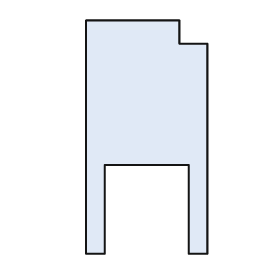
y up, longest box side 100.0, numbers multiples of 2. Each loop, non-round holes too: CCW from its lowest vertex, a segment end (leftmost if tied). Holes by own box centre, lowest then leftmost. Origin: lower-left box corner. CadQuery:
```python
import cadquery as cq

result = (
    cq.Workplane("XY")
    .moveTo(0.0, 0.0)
    .lineTo(8.0, 0.0)
    .lineTo(8.0, 38.0)
    .lineTo(44.0, 38.0)
    .lineTo(44.0, 0.0)
    .lineTo(52.0, 0.0)
    .lineTo(52.0, 90.0)
    .lineTo(40.0, 90.0)
    .lineTo(40.0, 100.0)
    .lineTo(0.0, 100.0)
    .close()
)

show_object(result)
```